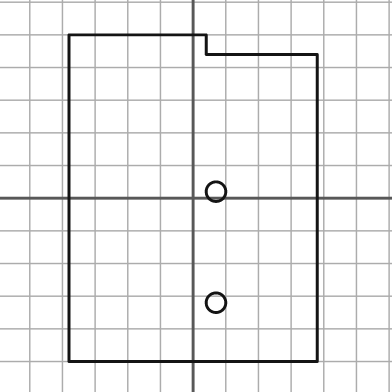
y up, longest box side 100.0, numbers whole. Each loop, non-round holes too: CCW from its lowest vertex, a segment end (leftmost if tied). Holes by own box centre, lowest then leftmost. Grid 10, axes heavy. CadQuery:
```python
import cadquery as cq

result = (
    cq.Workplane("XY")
    .moveTo(-38.0, -50.0)
    .lineTo(38.0, -50.0)
    .lineTo(38.0, 44.0)
    .lineTo(4.0, 44.0)
    .lineTo(4.0, 50.0)
    .lineTo(-38.0, 50.0)
    .close()
    .moveTo(7.0, -32.0)
    .circle(3.0)
    .moveTo(7.0, 2.0)
    .circle(3.0)
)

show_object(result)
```